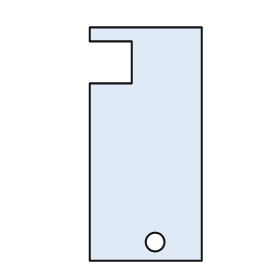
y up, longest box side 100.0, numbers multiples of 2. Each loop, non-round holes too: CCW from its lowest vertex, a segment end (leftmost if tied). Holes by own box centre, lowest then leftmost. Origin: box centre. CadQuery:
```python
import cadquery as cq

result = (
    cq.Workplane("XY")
    .moveTo(-24.0, -50.0)
    .lineTo(24.0, -50.0)
    .lineTo(24.0, 50.0)
    .lineTo(-24.0, 50.0)
    .lineTo(-24.0, 44.0)
    .lineTo(-6.0, 44.0)
    .lineTo(-6.0, 26.0)
    .lineTo(-24.0, 26.0)
    .close()
    .moveTo(4.0, -42.0)
    .circle(4.0)
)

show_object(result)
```